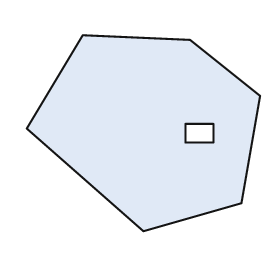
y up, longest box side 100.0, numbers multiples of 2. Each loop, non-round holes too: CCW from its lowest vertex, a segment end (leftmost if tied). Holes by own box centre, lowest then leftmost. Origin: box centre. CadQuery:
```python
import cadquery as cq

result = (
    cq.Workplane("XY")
    .moveTo(0.0, -42.0)
    .lineTo(42.0, -30.0)
    .lineTo(50.0, 16.0)
    .lineTo(20.0, 40.0)
    .lineTo(-26.0, 42.0)
    .lineTo(-50.0, 2.0)
    .close()
    .moveTo(18.0, -4.0)
    .lineTo(30.0, -4.0)
    .lineTo(30.0, 4.0)
    .lineTo(18.0, 4.0)
    .close()
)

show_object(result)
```